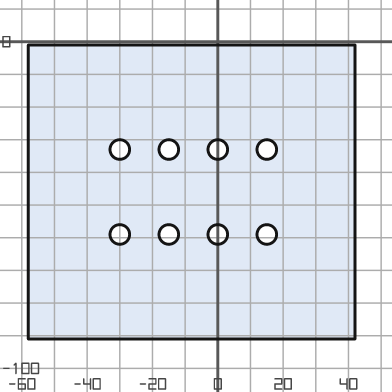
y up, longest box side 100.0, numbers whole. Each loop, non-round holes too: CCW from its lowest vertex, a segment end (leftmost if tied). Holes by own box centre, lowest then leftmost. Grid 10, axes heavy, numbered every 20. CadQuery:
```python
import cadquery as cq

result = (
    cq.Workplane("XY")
    .moveTo(-58.0, -91.0)
    .lineTo(42.0, -91.0)
    .lineTo(42.0, -1.0)
    .lineTo(-58.0, -1.0)
    .close()
    .moveTo(-30.0, -59.0)
    .circle(3.0)
    .moveTo(-15.0, -59.0)
    .circle(3.0)
    .moveTo(0.0, -59.0)
    .circle(3.0)
    .moveTo(15.0, -59.0)
    .circle(3.0)
    .moveTo(-30.0, -33.0)
    .circle(3.0)
    .moveTo(-15.0, -33.0)
    .circle(3.0)
    .moveTo(0.0, -33.0)
    .circle(3.0)
    .moveTo(15.0, -33.0)
    .circle(3.0)
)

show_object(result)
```